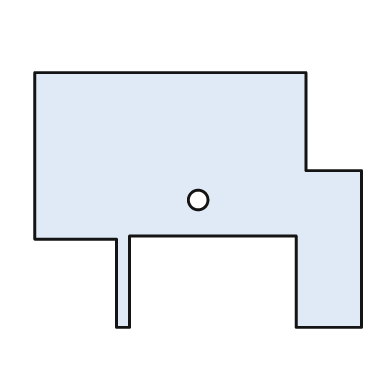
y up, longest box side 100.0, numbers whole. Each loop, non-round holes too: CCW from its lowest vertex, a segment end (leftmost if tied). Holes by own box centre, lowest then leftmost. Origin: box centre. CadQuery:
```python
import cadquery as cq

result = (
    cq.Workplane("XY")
    .moveTo(-25.0, -39.0)
    .lineTo(-21.0, -39.0)
    .lineTo(-21.0, -11.0)
    .lineTo(30.0, -11.0)
    .lineTo(30.0, -39.0)
    .lineTo(50.0, -39.0)
    .lineTo(50.0, 9.0)
    .lineTo(33.0, 9.0)
    .lineTo(33.0, 39.0)
    .lineTo(-50.0, 39.0)
    .lineTo(-50.0, -12.0)
    .lineTo(-25.0, -12.0)
    .close()
    .moveTo(0.0, 0.0)
    .circle(3.0)
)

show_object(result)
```